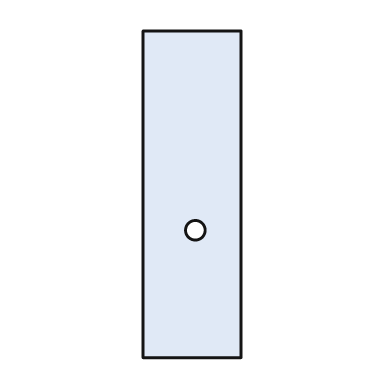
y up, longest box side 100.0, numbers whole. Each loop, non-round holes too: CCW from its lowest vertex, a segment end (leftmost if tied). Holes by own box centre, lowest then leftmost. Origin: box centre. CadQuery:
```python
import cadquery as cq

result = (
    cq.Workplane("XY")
    .moveTo(-15.0, -50.0)
    .lineTo(15.0, -50.0)
    .lineTo(15.0, 50.0)
    .lineTo(-15.0, 50.0)
    .close()
    .moveTo(1.0, -11.0)
    .circle(3.0)
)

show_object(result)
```